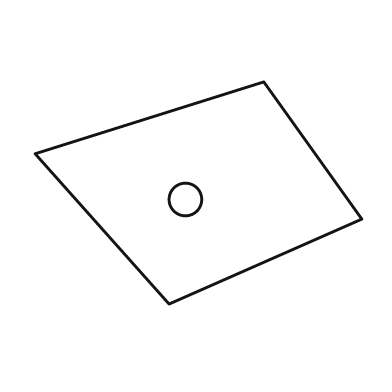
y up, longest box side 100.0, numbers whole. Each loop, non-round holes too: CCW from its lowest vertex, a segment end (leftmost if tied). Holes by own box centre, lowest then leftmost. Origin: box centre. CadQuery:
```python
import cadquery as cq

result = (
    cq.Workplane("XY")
    .moveTo(-9.0, -34.0)
    .lineTo(50.0, -8.0)
    .lineTo(20.0, 34.0)
    .lineTo(-50.0, 12.0)
    .close()
    .moveTo(-4.0, -2.0)
    .circle(5.0)
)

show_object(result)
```